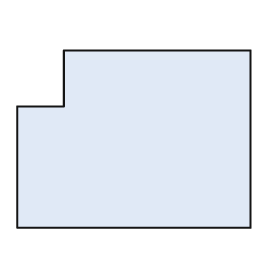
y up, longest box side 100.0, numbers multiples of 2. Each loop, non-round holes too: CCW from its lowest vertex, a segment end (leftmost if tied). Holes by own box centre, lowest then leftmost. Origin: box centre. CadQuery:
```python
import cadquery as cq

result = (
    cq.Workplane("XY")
    .moveTo(-50.0, -38.0)
    .lineTo(50.0, -38.0)
    .lineTo(50.0, 38.0)
    .lineTo(-30.0, 38.0)
    .lineTo(-30.0, 14.0)
    .lineTo(-50.0, 14.0)
    .close()
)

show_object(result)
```